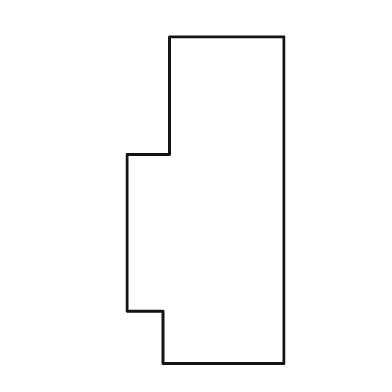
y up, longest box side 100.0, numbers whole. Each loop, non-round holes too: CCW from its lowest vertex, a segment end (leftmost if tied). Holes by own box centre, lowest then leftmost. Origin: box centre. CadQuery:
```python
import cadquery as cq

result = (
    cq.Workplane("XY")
    .moveTo(-13.0, -50.0)
    .lineTo(24.0, -50.0)
    .lineTo(24.0, 50.0)
    .lineTo(-11.0, 50.0)
    .lineTo(-11.0, 14.0)
    .lineTo(-24.0, 14.0)
    .lineTo(-24.0, -34.0)
    .lineTo(-13.0, -34.0)
    .close()
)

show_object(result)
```